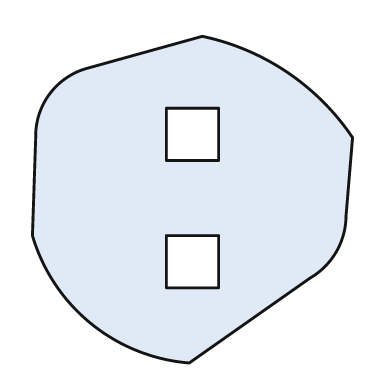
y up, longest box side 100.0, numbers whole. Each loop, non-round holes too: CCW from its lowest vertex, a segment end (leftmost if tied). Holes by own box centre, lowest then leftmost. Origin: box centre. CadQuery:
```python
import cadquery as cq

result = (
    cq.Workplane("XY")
    .moveTo(-1.0, -50.0)
    .lineTo(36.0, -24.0)
    .threePointArc((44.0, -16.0), (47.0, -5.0))
    .lineTo(49.0, 19.0)
    .threePointArc((29.0, 39.0), (3.0, 50.0))
    .lineTo(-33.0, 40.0)
    .threePointArc((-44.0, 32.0), (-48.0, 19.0))
    .lineTo(-49.0, -11.0)
    .threePointArc((-31.0, -38.0), (-1.0, -50.0))
    .close()
    .moveTo(-8.0, -27.0)
    .lineTo(8.0, -27.0)
    .lineTo(8.0, -11.0)
    .lineTo(-8.0, -11.0)
    .close()
    .moveTo(-8.0, 12.0)
    .lineTo(8.0, 12.0)
    .lineTo(8.0, 28.0)
    .lineTo(-8.0, 28.0)
    .close()
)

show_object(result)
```